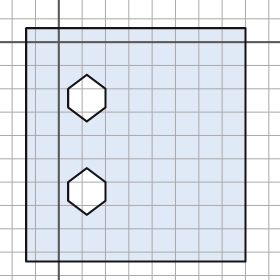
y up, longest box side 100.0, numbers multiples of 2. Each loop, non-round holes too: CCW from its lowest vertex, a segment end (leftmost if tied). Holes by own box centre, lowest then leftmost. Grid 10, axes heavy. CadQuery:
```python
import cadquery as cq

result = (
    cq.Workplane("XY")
    .moveTo(-14.0, -94.0)
    .lineTo(80.0, -94.0)
    .lineTo(80.0, 6.0)
    .lineTo(-14.0, 6.0)
    .close()
    .moveTo(12.0, -74.0)
    .lineTo(20.0, -68.0)
    .lineTo(20.0, -60.0)
    .lineTo(12.0, -54.0)
    .lineTo(4.0, -60.0)
    .lineTo(4.0, -68.0)
    .close()
    .moveTo(12.0, -34.0)
    .lineTo(20.0, -28.0)
    .lineTo(20.0, -20.0)
    .lineTo(12.0, -14.0)
    .lineTo(4.0, -20.0)
    .lineTo(4.0, -28.0)
    .close()
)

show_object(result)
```